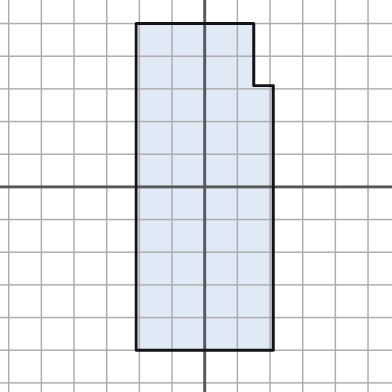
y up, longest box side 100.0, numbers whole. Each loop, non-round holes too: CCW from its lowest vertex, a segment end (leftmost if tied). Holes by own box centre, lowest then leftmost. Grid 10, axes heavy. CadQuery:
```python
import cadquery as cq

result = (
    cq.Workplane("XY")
    .moveTo(-21.0, -50.0)
    .lineTo(21.0, -50.0)
    .lineTo(21.0, 31.0)
    .lineTo(15.0, 31.0)
    .lineTo(15.0, 50.0)
    .lineTo(-21.0, 50.0)
    .close()
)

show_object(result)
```